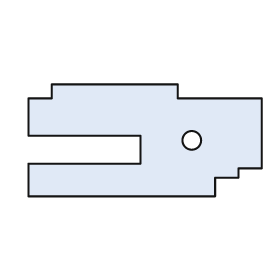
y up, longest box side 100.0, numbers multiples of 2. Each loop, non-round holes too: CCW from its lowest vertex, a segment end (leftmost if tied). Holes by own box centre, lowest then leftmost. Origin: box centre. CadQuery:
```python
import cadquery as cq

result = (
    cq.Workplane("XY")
    .moveTo(-50.0, -24.0)
    .lineTo(30.0, -24.0)
    .lineTo(30.0, -16.0)
    .lineTo(40.0, -16.0)
    .lineTo(40.0, -12.0)
    .lineTo(50.0, -12.0)
    .lineTo(50.0, 18.0)
    .lineTo(14.0, 18.0)
    .lineTo(14.0, 24.0)
    .lineTo(-40.0, 24.0)
    .lineTo(-40.0, 18.0)
    .lineTo(-50.0, 18.0)
    .lineTo(-50.0, 2.0)
    .lineTo(-2.0, 2.0)
    .lineTo(-2.0, -10.0)
    .lineTo(-50.0, -10.0)
    .close()
    .moveTo(20.0, 0.0)
    .circle(4.0)
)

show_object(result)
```